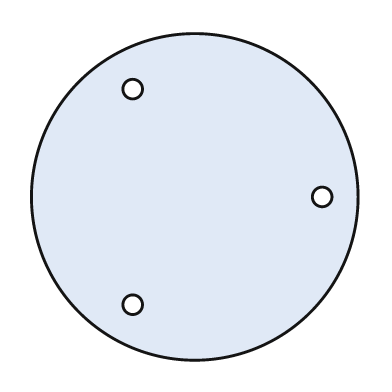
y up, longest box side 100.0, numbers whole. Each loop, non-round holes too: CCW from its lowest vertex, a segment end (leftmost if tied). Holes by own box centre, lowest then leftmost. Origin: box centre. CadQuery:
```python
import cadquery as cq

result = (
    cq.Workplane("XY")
    .moveTo(0.0, 0.0)
    .circle(50.0)
    .moveTo(-19.0, -33.0)
    .circle(3.0)
    .moveTo(39.0, 0.0)
    .circle(3.0)
    .moveTo(-19.0, 33.0)
    .circle(3.0)
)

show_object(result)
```